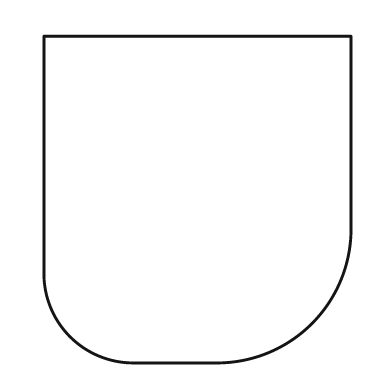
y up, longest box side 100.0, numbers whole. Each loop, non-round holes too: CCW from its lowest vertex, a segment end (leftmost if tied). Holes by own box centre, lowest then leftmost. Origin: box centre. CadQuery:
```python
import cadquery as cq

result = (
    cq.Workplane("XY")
    .moveTo(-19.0, -50.0)
    .lineTo(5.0, -50.0)
    .threePointArc((35.0, -38.0), (47.0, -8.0))
    .lineTo(47.0, 50.0)
    .lineTo(-47.0, 50.0)
    .lineTo(-47.0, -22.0)
    .threePointArc((-39.0, -42.0), (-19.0, -50.0))
    .close()
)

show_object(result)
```